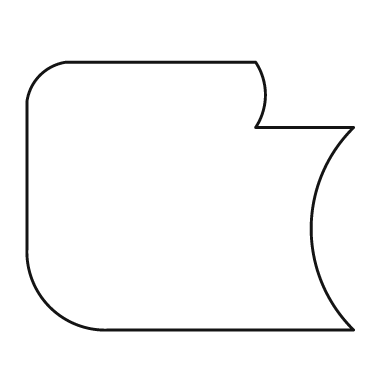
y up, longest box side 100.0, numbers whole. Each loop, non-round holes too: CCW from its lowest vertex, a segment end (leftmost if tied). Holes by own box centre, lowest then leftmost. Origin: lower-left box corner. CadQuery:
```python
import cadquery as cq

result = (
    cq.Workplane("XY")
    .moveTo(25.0, 0.0)
    .lineTo(100.0, 0.0)
    .threePointArc((87.0, 31.0), (100.0, 62.0))
    .lineTo(70.0, 62.0)
    .threePointArc((73.0, 72.0), (70.0, 82.0))
    .lineTo(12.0, 82.0)
    .threePointArc((4.0, 78.0), (0.0, 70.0))
    .lineTo(0.0, 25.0)
    .threePointArc((7.0, 7.0), (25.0, 0.0))
    .close()
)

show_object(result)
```